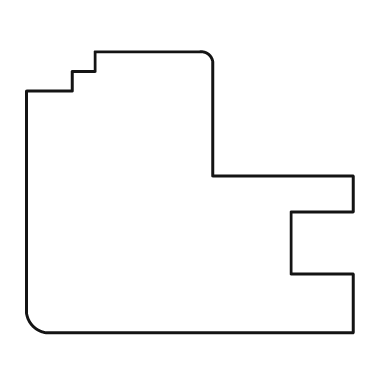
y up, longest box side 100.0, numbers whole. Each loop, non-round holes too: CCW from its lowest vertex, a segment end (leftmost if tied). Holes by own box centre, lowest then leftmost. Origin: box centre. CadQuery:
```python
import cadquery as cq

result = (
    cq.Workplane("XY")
    .moveTo(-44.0, -43.0)
    .lineTo(50.0, -43.0)
    .lineTo(50.0, -25.0)
    .lineTo(31.0, -25.0)
    .lineTo(31.0, -6.0)
    .lineTo(50.0, -6.0)
    .lineTo(50.0, 5.0)
    .lineTo(7.0, 5.0)
    .lineTo(7.0, 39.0)
    .threePointArc((6.0, 42.0), (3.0, 43.0))
    .lineTo(-29.0, 43.0)
    .lineTo(-29.0, 37.0)
    .lineTo(-36.0, 37.0)
    .lineTo(-36.0, 31.0)
    .lineTo(-50.0, 31.0)
    .lineTo(-50.0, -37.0)
    .threePointArc((-48.0, -41.0), (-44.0, -43.0))
    .close()
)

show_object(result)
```